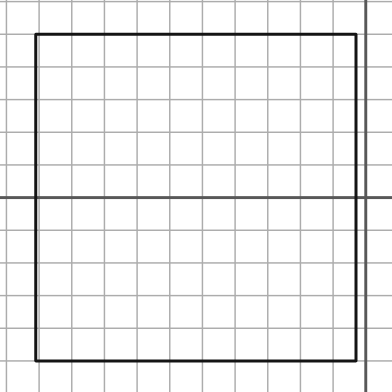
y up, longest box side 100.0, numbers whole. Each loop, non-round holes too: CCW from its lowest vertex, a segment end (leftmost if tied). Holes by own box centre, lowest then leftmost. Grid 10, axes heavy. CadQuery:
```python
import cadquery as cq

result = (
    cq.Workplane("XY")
    .moveTo(-101.0, -50.0)
    .lineTo(-3.0, -50.0)
    .lineTo(-3.0, 50.0)
    .lineTo(-101.0, 50.0)
    .close()
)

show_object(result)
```